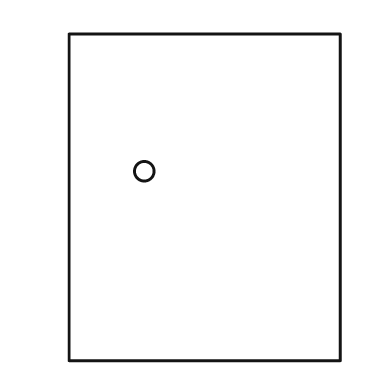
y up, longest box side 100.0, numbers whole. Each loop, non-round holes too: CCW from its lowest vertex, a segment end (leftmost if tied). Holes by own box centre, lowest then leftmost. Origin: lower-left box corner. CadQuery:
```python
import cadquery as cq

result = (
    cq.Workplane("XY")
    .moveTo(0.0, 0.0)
    .lineTo(83.0, 0.0)
    .lineTo(83.0, 100.0)
    .lineTo(0.0, 100.0)
    .close()
    .moveTo(23.0, 58.0)
    .circle(3.0)
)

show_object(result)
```